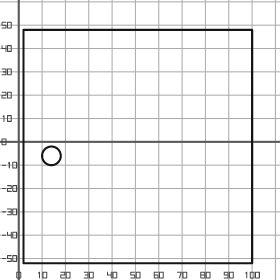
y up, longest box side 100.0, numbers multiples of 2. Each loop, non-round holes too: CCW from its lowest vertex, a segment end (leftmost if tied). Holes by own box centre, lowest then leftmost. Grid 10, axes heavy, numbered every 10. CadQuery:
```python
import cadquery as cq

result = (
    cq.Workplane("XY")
    .moveTo(2.0, -52.0)
    .lineTo(100.0, -52.0)
    .lineTo(100.0, 48.0)
    .lineTo(2.0, 48.0)
    .close()
    .moveTo(14.0, -6.0)
    .circle(4.0)
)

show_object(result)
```